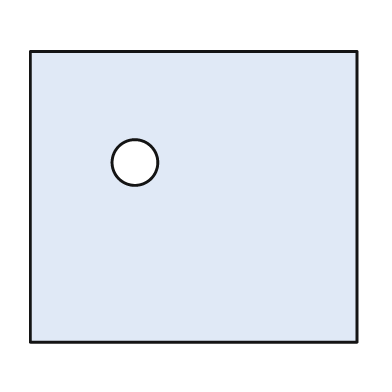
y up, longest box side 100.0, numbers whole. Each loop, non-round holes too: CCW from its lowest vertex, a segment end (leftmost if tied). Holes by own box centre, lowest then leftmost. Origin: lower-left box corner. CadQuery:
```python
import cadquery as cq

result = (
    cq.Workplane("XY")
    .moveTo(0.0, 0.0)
    .lineTo(100.0, 0.0)
    .lineTo(100.0, 89.0)
    .lineTo(0.0, 89.0)
    .close()
    .moveTo(32.0, 55.0)
    .circle(7.0)
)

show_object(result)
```